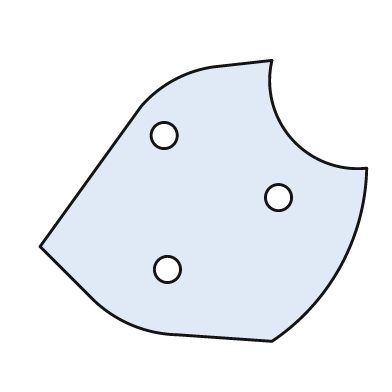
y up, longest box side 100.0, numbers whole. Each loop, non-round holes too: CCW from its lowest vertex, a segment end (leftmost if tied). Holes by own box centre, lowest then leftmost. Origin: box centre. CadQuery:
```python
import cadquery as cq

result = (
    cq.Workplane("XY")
    .moveTo(21.0, -43.0)
    .threePointArc((42.0, -20.0), (50.0, 10.0))
    .threePointArc((27.0, 19.0), (21.0, 43.0))
    .lineTo(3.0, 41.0)
    .threePointArc((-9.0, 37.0), (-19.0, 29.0))
    .lineTo(-50.0, -14.0)
    .lineTo(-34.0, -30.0)
    .threePointArc((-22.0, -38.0), (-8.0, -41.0))
    .close()
    .moveTo(-11.0, -21.0)
    .circle(4.0)
    .moveTo(23.0, 1.0)
    .circle(4.0)
    .moveTo(-12.0, 20.0)
    .circle(4.0)
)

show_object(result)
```